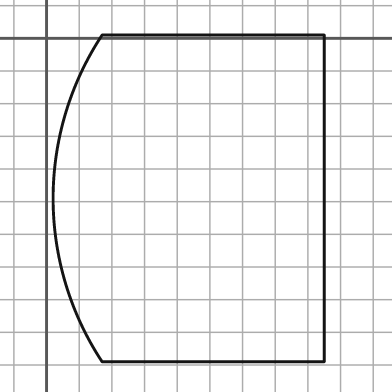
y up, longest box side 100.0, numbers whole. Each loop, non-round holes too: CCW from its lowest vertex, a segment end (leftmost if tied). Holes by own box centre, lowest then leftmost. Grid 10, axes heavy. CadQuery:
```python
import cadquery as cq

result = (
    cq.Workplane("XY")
    .moveTo(17.0, -99.0)
    .lineTo(85.0, -99.0)
    .lineTo(85.0, 1.0)
    .lineTo(17.0, 1.0)
    .threePointArc((2.0, -49.0), (17.0, -99.0))
    .close()
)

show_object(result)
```